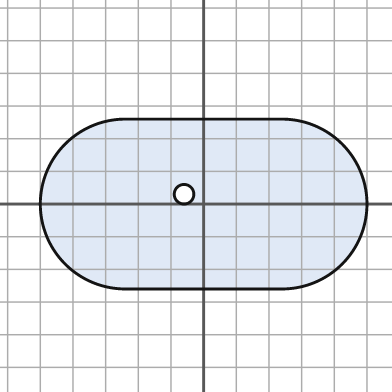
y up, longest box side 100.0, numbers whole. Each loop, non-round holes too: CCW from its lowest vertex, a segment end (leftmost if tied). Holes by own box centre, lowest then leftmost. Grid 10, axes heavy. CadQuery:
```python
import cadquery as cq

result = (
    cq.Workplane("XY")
    .moveTo(-24.0, -26.0)
    .lineTo(24.0, -26.0)
    .threePointArc((50.0, 0.0), (24.0, 26.0))
    .lineTo(-24.0, 26.0)
    .threePointArc((-50.0, 0.0), (-24.0, -26.0))
    .close()
    .moveTo(-6.0, 3.0)
    .circle(3.0)
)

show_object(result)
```